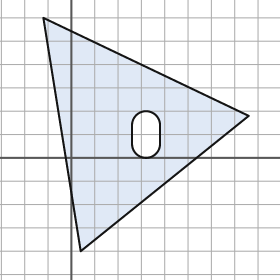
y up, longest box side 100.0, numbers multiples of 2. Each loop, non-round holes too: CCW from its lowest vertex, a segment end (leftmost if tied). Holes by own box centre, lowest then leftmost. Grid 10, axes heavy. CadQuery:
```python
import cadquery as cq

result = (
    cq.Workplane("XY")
    .moveTo(4.0, -40.0)
    .lineTo(76.0, 18.0)
    .lineTo(-12.0, 60.0)
    .close()
    .moveTo(26.0, 6.0)
    .threePointArc((32.0, 0.0), (38.0, 6.0))
    .lineTo(38.0, 14.0)
    .threePointArc((32.0, 20.0), (26.0, 14.0))
    .close()
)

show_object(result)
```